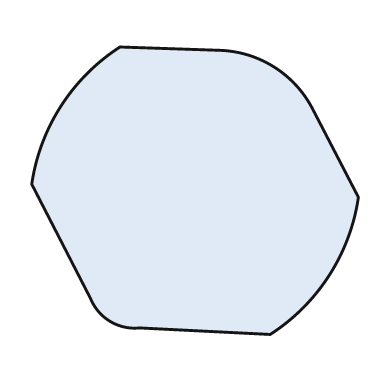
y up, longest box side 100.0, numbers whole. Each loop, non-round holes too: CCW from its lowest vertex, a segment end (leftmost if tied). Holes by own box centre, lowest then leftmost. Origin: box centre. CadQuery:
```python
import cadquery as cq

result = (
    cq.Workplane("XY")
    .moveTo(23.0, -44.0)
    .threePointArc((41.0, -26.0), (50.0, -2.0))
    .lineTo(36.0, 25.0)
    .threePointArc((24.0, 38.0), (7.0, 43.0))
    .lineTo(-23.0, 44.0)
    .threePointArc((-41.0, 26.0), (-50.0, 2.0))
    .lineTo(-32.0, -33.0)
    .threePointArc((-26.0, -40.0), (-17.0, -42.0))
    .close()
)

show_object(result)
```